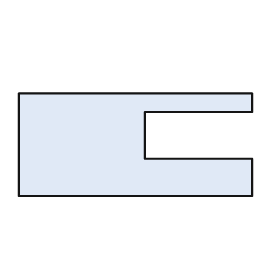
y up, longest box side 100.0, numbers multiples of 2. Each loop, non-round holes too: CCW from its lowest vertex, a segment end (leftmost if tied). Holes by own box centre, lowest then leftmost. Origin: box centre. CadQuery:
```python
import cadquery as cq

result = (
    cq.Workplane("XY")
    .moveTo(-50.0, -22.0)
    .lineTo(50.0, -22.0)
    .lineTo(50.0, -6.0)
    .lineTo(4.0, -6.0)
    .lineTo(4.0, 14.0)
    .lineTo(50.0, 14.0)
    .lineTo(50.0, 22.0)
    .lineTo(-50.0, 22.0)
    .close()
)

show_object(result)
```